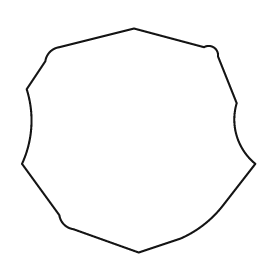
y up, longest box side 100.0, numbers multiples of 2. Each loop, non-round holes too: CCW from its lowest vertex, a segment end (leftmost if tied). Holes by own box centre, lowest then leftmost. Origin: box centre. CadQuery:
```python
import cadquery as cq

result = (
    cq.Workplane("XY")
    .moveTo(0.0, -48.0)
    .lineTo(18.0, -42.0)
    .threePointArc((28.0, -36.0), (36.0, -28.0))
    .lineTo(50.0, -10.0)
    .threePointArc((42.0, 2.0), (42.0, 16.0))
    .lineTo(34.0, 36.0)
    .threePointArc((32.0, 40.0), (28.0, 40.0))
    .lineTo(-2.0, 48.0)
    .lineTo(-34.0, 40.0)
    .threePointArc((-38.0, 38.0), (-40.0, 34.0))
    .lineTo(-48.0, 22.0)
    .threePointArc((-46.0, 6.0), (-50.0, -10.0))
    .lineTo(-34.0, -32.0)
    .threePointArc((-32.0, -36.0), (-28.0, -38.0))
    .close()
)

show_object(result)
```